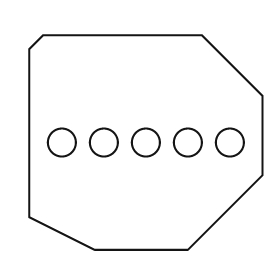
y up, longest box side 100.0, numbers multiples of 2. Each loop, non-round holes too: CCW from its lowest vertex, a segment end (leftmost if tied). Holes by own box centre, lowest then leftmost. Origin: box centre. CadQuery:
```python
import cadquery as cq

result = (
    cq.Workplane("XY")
    .moveTo(-22.0, -46.0)
    .lineTo(18.0, -46.0)
    .lineTo(50.0, -14.0)
    .lineTo(50.0, 20.0)
    .lineTo(24.0, 46.0)
    .lineTo(-44.0, 46.0)
    .lineTo(-50.0, 40.0)
    .lineTo(-50.0, -32.0)
    .close()
    .moveTo(-36.0, 0.0)
    .circle(6.0)
    .moveTo(-18.0, 0.0)
    .circle(6.0)
    .moveTo(0.0, 0.0)
    .circle(6.0)
    .moveTo(18.0, 0.0)
    .circle(6.0)
    .moveTo(36.0, 0.0)
    .circle(6.0)
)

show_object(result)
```